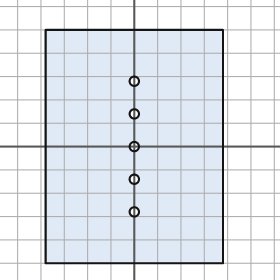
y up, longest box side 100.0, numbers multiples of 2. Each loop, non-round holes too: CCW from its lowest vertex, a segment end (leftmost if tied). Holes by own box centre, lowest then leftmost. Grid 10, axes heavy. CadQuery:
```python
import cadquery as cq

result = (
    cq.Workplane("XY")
    .moveTo(-38.0, -50.0)
    .lineTo(38.0, -50.0)
    .lineTo(38.0, 50.0)
    .lineTo(-38.0, 50.0)
    .close()
    .moveTo(0.0, -28.0)
    .circle(2.0)
    .moveTo(0.0, -14.0)
    .circle(2.0)
    .moveTo(0.0, 0.0)
    .circle(2.0)
    .moveTo(0.0, 14.0)
    .circle(2.0)
    .moveTo(0.0, 28.0)
    .circle(2.0)
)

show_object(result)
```